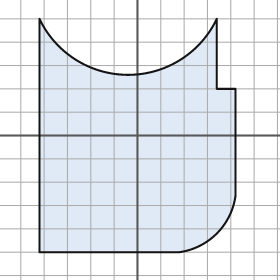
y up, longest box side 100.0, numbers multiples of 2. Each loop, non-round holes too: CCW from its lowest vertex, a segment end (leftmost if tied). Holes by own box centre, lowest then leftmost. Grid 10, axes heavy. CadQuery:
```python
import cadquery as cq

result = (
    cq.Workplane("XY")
    .moveTo(-42.0, -50.0)
    .lineTo(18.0, -50.0)
    .threePointArc((34.0, -42.0), (42.0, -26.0))
    .lineTo(42.0, 20.0)
    .lineTo(34.0, 20.0)
    .lineTo(34.0, 50.0)
    .threePointArc((-4.0, 26.0), (-42.0, 50.0))
    .close()
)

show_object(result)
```